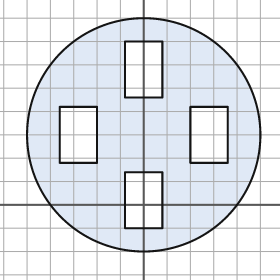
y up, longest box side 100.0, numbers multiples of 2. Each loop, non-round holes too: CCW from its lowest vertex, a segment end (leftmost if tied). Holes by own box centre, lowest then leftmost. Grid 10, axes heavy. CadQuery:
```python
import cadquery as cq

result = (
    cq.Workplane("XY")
    .moveTo(0.0, 30.0)
    .circle(50.0)
    .moveTo(-8.0, -10.0)
    .lineTo(8.0, -10.0)
    .lineTo(8.0, 14.0)
    .lineTo(-8.0, 14.0)
    .close()
    .moveTo(-36.0, 18.0)
    .lineTo(-20.0, 18.0)
    .lineTo(-20.0, 42.0)
    .lineTo(-36.0, 42.0)
    .close()
    .moveTo(20.0, 18.0)
    .lineTo(36.0, 18.0)
    .lineTo(36.0, 42.0)
    .lineTo(20.0, 42.0)
    .close()
    .moveTo(-8.0, 46.0)
    .lineTo(8.0, 46.0)
    .lineTo(8.0, 70.0)
    .lineTo(-8.0, 70.0)
    .close()
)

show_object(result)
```